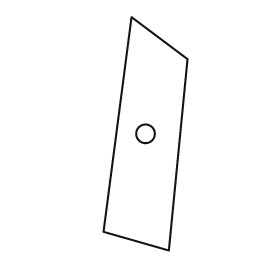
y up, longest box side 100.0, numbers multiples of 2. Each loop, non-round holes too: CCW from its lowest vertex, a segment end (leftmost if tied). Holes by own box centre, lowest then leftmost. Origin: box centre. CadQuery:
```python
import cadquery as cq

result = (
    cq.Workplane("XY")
    .moveTo(10.0, -50.0)
    .lineTo(18.0, 32.0)
    .lineTo(-6.0, 50.0)
    .lineTo(-18.0, -42.0)
    .close()
    .moveTo(0.0, 0.0)
    .circle(4.0)
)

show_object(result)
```